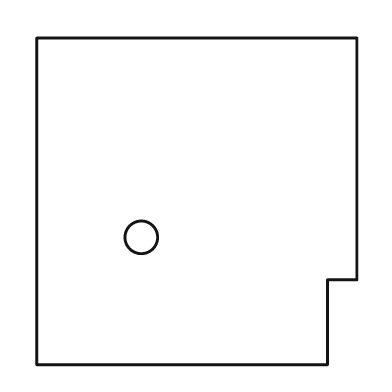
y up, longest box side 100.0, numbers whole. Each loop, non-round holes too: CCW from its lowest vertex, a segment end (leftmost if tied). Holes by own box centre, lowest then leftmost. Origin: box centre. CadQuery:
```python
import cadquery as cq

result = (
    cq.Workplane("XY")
    .moveTo(-49.0, -50.0)
    .lineTo(40.0, -50.0)
    .lineTo(40.0, -24.0)
    .lineTo(49.0, -24.0)
    .lineTo(49.0, 50.0)
    .lineTo(-49.0, 50.0)
    .close()
    .moveTo(-17.0, -11.0)
    .circle(5.0)
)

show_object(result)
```